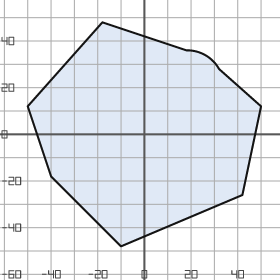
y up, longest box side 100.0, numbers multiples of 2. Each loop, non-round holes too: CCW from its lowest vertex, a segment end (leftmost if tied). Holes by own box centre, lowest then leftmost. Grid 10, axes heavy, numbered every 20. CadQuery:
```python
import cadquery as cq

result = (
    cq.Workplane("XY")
    .moveTo(-10.0, -48.0)
    .lineTo(42.0, -26.0)
    .lineTo(50.0, 12.0)
    .lineTo(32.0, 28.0)
    .threePointArc((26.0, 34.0), (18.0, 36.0))
    .lineTo(-18.0, 48.0)
    .lineTo(-50.0, 12.0)
    .lineTo(-40.0, -18.0)
    .close()
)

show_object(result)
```